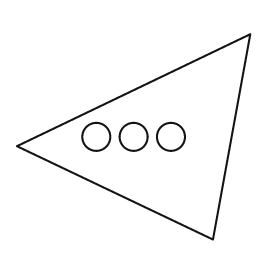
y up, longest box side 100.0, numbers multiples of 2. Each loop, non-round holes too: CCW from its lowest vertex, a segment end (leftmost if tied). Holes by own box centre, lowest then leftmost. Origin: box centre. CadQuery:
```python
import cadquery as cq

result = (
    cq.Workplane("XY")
    .moveTo(34.0, -44.0)
    .lineTo(50.0, 44.0)
    .lineTo(-50.0, -4.0)
    .close()
    .moveTo(-16.0, 0.0)
    .circle(6.0)
    .moveTo(0.0, 0.0)
    .circle(6.0)
    .moveTo(16.0, 0.0)
    .circle(6.0)
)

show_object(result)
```